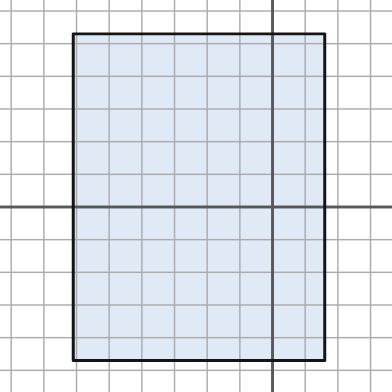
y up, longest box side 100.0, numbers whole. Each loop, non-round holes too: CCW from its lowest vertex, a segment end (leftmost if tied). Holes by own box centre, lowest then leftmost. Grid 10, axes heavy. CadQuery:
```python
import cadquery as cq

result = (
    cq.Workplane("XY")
    .moveTo(-61.0, -47.0)
    .lineTo(16.0, -47.0)
    .lineTo(16.0, 53.0)
    .lineTo(-61.0, 53.0)
    .close()
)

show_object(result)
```